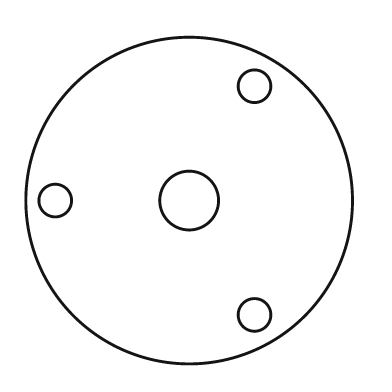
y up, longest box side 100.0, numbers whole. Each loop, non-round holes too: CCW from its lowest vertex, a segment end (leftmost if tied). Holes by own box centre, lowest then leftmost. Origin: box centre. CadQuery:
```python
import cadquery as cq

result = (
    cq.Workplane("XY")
    .moveTo(0.0, 0.0)
    .circle(50.0)
    .moveTo(20.0, -35.0)
    .circle(5.0)
    .moveTo(-41.0, 0.0)
    .circle(5.0)
    .moveTo(0.0, 0.0)
    .circle(9.0)
    .moveTo(20.0, 35.0)
    .circle(5.0)
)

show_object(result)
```